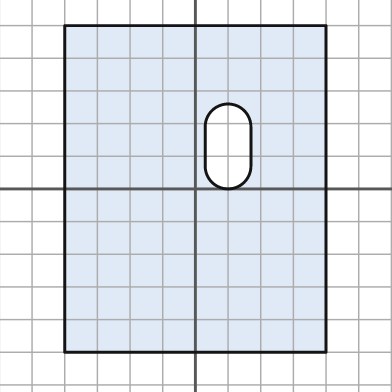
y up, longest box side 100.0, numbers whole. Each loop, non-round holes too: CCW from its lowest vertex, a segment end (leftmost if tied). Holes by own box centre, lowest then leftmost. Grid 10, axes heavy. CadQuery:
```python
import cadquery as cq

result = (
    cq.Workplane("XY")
    .moveTo(-40.0, -50.0)
    .lineTo(40.0, -50.0)
    .lineTo(40.0, 50.0)
    .lineTo(-40.0, 50.0)
    .close()
    .moveTo(3.0, 7.0)
    .threePointArc((10.0, 0.0), (17.0, 7.0))
    .lineTo(17.0, 19.0)
    .threePointArc((10.0, 26.0), (3.0, 19.0))
    .close()
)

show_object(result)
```